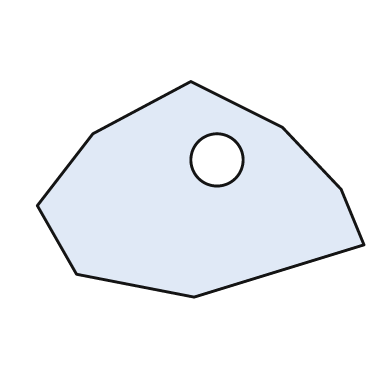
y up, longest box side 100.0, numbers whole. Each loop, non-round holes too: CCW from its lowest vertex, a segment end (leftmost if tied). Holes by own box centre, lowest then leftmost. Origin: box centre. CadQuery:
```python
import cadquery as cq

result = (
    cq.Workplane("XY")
    .moveTo(-2.0, -33.0)
    .lineTo(50.0, -17.0)
    .lineTo(43.0, 0.0)
    .lineTo(25.0, 19.0)
    .lineTo(-3.0, 33.0)
    .lineTo(-33.0, 17.0)
    .lineTo(-50.0, -5.0)
    .lineTo(-38.0, -26.0)
    .close()
    .moveTo(5.0, 9.0)
    .circle(8.0)
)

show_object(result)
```